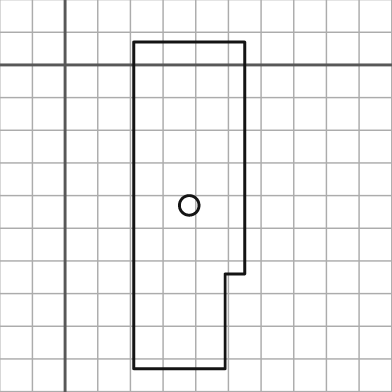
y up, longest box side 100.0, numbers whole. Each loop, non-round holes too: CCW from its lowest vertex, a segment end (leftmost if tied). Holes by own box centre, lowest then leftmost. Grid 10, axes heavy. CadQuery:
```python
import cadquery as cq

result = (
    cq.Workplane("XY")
    .moveTo(21.0, -93.0)
    .lineTo(49.0, -93.0)
    .lineTo(49.0, -64.0)
    .lineTo(55.0, -64.0)
    .lineTo(55.0, 7.0)
    .lineTo(21.0, 7.0)
    .close()
    .moveTo(38.0, -43.0)
    .circle(3.0)
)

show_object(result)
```